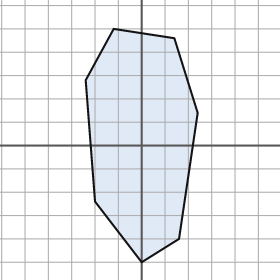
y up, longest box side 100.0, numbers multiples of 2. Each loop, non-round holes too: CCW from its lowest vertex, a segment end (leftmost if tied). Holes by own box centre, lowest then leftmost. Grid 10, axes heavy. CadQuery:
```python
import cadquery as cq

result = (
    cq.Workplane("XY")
    .moveTo(0.0, -50.0)
    .lineTo(16.0, -40.0)
    .lineTo(24.0, 14.0)
    .lineTo(14.0, 46.0)
    .lineTo(-12.0, 50.0)
    .lineTo(-24.0, 28.0)
    .lineTo(-20.0, -24.0)
    .close()
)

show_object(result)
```